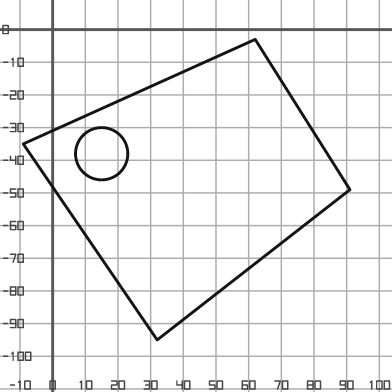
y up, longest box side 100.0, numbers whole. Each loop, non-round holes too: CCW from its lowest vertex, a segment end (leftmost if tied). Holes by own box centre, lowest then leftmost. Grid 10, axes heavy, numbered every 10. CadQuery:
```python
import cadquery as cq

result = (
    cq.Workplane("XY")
    .moveTo(32.0, -95.0)
    .lineTo(91.0, -49.0)
    .lineTo(62.0, -3.0)
    .lineTo(-9.0, -35.0)
    .close()
    .moveTo(15.0, -38.0)
    .circle(8.0)
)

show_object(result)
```